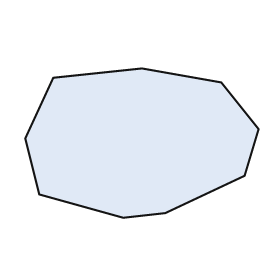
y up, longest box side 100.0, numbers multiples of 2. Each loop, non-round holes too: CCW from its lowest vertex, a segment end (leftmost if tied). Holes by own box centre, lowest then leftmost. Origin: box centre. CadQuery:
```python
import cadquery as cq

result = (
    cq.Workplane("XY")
    .moveTo(-8.0, -32.0)
    .lineTo(10.0, -30.0)
    .lineTo(44.0, -14.0)
    .lineTo(50.0, 6.0)
    .lineTo(34.0, 26.0)
    .lineTo(0.0, 32.0)
    .lineTo(-38.0, 28.0)
    .lineTo(-50.0, 2.0)
    .lineTo(-44.0, -22.0)
    .close()
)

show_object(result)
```